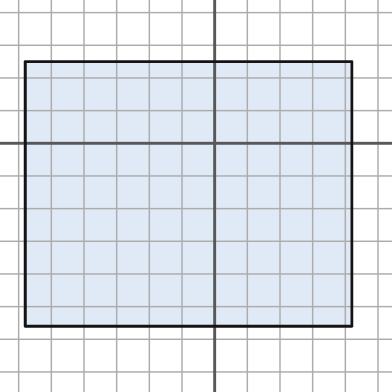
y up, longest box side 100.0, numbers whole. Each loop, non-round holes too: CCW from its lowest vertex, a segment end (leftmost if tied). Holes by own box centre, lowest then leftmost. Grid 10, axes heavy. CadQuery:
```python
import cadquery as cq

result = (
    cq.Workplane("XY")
    .moveTo(-58.0, -56.0)
    .lineTo(42.0, -56.0)
    .lineTo(42.0, 25.0)
    .lineTo(-58.0, 25.0)
    .close()
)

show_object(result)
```